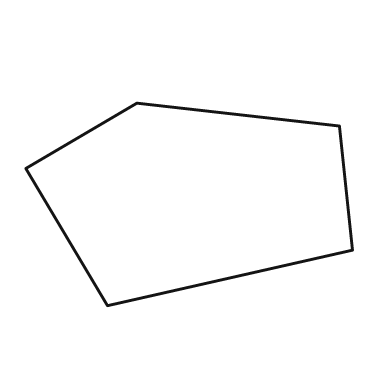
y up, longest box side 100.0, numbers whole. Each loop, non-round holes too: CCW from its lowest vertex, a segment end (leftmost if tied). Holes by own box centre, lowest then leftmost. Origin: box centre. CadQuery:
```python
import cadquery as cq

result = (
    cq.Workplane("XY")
    .moveTo(-25.0, -31.0)
    .lineTo(50.0, -14.0)
    .lineTo(46.0, 24.0)
    .lineTo(-16.0, 31.0)
    .lineTo(-50.0, 11.0)
    .close()
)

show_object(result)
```